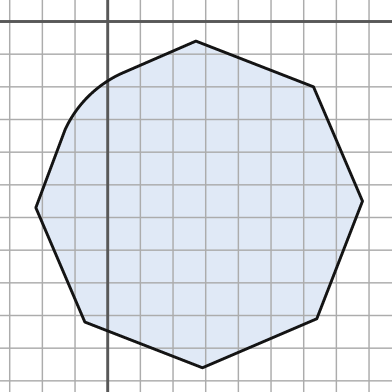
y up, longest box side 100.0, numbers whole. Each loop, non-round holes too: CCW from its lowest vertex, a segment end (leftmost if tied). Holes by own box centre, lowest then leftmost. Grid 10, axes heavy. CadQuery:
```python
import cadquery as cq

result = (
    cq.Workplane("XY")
    .moveTo(29.0, -106.0)
    .lineTo(64.0, -91.0)
    .lineTo(78.0, -55.0)
    .lineTo(63.0, -20.0)
    .lineTo(27.0, -6.0)
    .lineTo(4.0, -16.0)
    .threePointArc((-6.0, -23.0), (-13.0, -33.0))
    .lineTo(-22.0, -57.0)
    .lineTo(-7.0, -92.0)
    .close()
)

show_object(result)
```